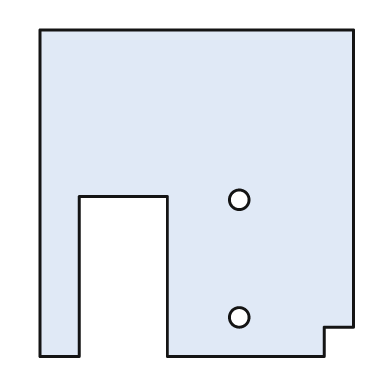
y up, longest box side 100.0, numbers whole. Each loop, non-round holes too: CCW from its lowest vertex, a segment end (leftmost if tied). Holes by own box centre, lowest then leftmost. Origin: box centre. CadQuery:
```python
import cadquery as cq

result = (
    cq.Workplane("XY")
    .moveTo(-48.0, -50.0)
    .lineTo(-36.0, -50.0)
    .lineTo(-36.0, -1.0)
    .lineTo(-9.0, -1.0)
    .lineTo(-9.0, -50.0)
    .lineTo(39.0, -50.0)
    .lineTo(39.0, -41.0)
    .lineTo(48.0, -41.0)
    .lineTo(48.0, 50.0)
    .lineTo(-48.0, 50.0)
    .close()
    .moveTo(13.0, -38.0)
    .circle(3.0)
    .moveTo(13.0, -2.0)
    .circle(3.0)
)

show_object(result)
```